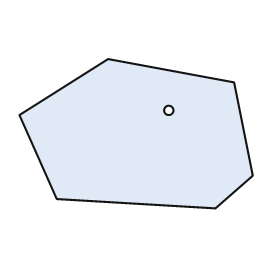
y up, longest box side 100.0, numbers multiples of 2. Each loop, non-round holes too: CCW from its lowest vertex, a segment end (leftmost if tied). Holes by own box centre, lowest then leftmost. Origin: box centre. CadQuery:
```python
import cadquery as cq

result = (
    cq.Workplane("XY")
    .moveTo(34.0, -32.0)
    .lineTo(50.0, -18.0)
    .lineTo(42.0, 22.0)
    .lineTo(-12.0, 32.0)
    .lineTo(-50.0, 8.0)
    .lineTo(-34.0, -28.0)
    .close()
    .moveTo(14.0, 10.0)
    .circle(2.0)
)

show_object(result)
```